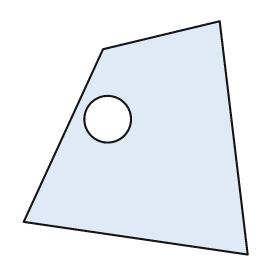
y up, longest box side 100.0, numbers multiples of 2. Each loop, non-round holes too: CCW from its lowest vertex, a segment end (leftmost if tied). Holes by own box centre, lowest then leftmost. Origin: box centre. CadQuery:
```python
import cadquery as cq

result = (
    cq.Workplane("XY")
    .moveTo(48.0, -50.0)
    .lineTo(36.0, 50.0)
    .lineTo(-14.0, 38.0)
    .lineTo(-48.0, -36.0)
    .close()
    .moveTo(-12.0, 8.0)
    .circle(10.0)
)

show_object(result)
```